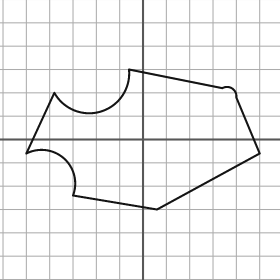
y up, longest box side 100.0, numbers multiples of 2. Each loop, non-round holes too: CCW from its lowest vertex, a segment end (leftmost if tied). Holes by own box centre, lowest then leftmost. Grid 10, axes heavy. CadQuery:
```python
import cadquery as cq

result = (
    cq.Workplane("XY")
    .moveTo(6.0, -30.0)
    .lineTo(50.0, -6.0)
    .lineTo(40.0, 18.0)
    .threePointArc((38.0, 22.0), (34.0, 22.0))
    .lineTo(-6.0, 30.0)
    .threePointArc((-18.0, 12.0), (-38.0, 20.0))
    .lineTo(-50.0, -6.0)
    .threePointArc((-34.0, -8.0), (-30.0, -24.0))
    .close()
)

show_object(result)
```